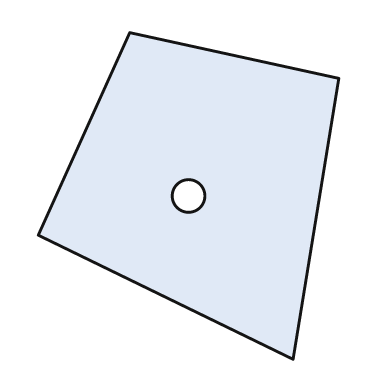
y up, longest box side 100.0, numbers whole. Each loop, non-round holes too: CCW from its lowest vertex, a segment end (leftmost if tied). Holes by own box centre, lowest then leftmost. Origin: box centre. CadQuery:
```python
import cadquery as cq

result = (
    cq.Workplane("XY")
    .moveTo(32.0, -50.0)
    .lineTo(46.0, 36.0)
    .lineTo(-18.0, 50.0)
    .lineTo(-46.0, -12.0)
    .close()
    .moveTo(0.0, 0.0)
    .circle(5.0)
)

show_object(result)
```